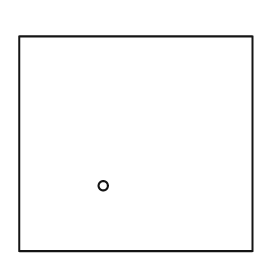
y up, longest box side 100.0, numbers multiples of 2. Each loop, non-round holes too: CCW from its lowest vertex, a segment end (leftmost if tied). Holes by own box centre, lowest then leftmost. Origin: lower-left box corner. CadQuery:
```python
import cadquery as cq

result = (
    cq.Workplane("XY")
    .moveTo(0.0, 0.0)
    .lineTo(100.0, 0.0)
    .lineTo(100.0, 92.0)
    .lineTo(0.0, 92.0)
    .close()
    .moveTo(36.0, 28.0)
    .circle(2.0)
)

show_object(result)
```